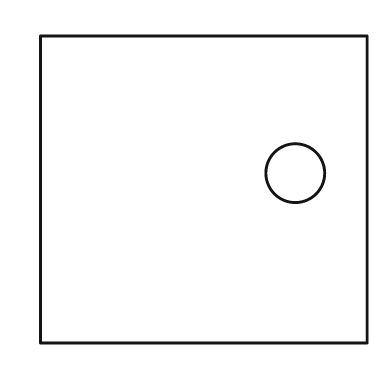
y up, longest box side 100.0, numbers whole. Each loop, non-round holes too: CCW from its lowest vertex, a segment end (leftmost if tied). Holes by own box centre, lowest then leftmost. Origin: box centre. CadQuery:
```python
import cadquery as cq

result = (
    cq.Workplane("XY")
    .moveTo(-50.0, -47.0)
    .lineTo(50.0, -47.0)
    .lineTo(50.0, 47.0)
    .lineTo(-50.0, 47.0)
    .close()
    .moveTo(28.0, 5.0)
    .circle(9.0)
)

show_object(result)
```